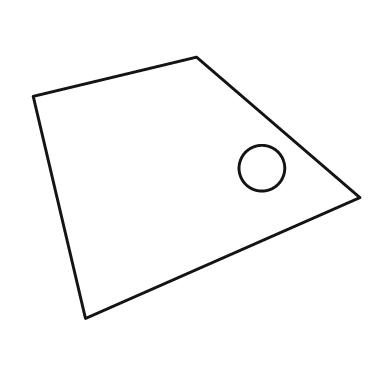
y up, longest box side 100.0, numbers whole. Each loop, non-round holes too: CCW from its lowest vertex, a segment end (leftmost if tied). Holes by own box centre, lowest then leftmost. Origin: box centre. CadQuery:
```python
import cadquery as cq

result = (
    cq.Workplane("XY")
    .moveTo(-34.0, -40.0)
    .lineTo(50.0, -3.0)
    .lineTo(0.0, 40.0)
    .lineTo(-50.0, 28.0)
    .close()
    .moveTo(20.0, 6.0)
    .circle(7.0)
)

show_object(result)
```